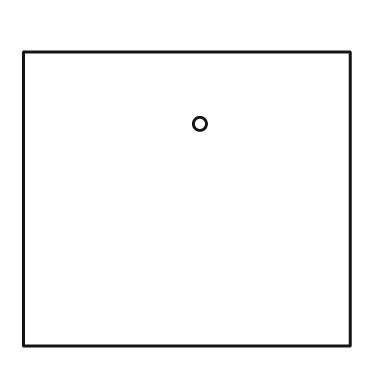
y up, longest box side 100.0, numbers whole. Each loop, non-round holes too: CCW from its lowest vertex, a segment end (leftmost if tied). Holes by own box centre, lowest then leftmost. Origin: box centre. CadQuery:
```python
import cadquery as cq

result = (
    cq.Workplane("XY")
    .moveTo(-50.0, -45.0)
    .lineTo(50.0, -45.0)
    .lineTo(50.0, 45.0)
    .lineTo(-50.0, 45.0)
    .close()
    .moveTo(4.0, 23.0)
    .circle(2.0)
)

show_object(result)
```